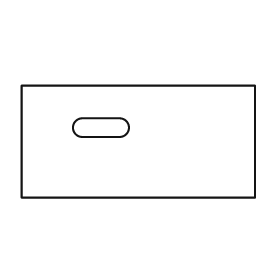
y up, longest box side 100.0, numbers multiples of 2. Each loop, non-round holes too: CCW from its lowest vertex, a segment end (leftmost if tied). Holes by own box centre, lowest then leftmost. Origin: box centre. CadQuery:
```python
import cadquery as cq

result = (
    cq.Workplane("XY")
    .moveTo(-50.0, -24.0)
    .lineTo(50.0, -24.0)
    .lineTo(50.0, 24.0)
    .lineTo(-50.0, 24.0)
    .close()
    .moveTo(-24.0, 2.0)
    .lineTo(-8.0, 2.0)
    .threePointArc((-4.0, 6.0), (-8.0, 10.0))
    .lineTo(-24.0, 10.0)
    .threePointArc((-28.0, 6.0), (-24.0, 2.0))
    .close()
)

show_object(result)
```